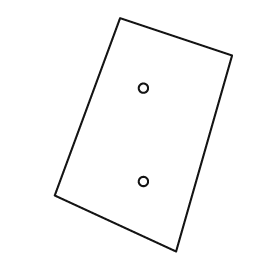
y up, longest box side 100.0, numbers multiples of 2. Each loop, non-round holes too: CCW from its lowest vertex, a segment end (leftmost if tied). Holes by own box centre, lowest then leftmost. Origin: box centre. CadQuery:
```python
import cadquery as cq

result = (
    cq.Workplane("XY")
    .moveTo(14.0, -50.0)
    .lineTo(38.0, 34.0)
    .lineTo(-10.0, 50.0)
    .lineTo(-38.0, -26.0)
    .close()
    .moveTo(0.0, -20.0)
    .circle(2.0)
    .moveTo(0.0, 20.0)
    .circle(2.0)
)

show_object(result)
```